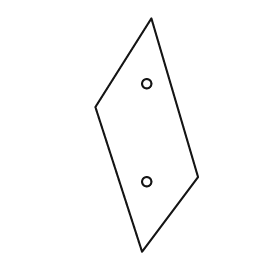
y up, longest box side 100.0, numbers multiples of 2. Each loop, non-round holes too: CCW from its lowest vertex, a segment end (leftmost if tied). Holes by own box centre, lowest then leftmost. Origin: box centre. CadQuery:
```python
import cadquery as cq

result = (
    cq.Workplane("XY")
    .moveTo(-2.0, -50.0)
    .lineTo(22.0, -18.0)
    .lineTo(2.0, 50.0)
    .lineTo(-22.0, 12.0)
    .close()
    .moveTo(0.0, -20.0)
    .circle(2.0)
    .moveTo(0.0, 22.0)
    .circle(2.0)
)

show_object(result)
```